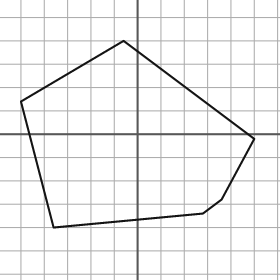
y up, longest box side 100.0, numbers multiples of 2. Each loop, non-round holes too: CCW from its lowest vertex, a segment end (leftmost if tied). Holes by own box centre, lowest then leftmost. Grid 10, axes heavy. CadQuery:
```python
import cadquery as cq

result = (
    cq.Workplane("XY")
    .moveTo(-36.0, -40.0)
    .lineTo(28.0, -34.0)
    .lineTo(36.0, -28.0)
    .lineTo(50.0, -2.0)
    .lineTo(-6.0, 40.0)
    .lineTo(-50.0, 14.0)
    .close()
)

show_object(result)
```